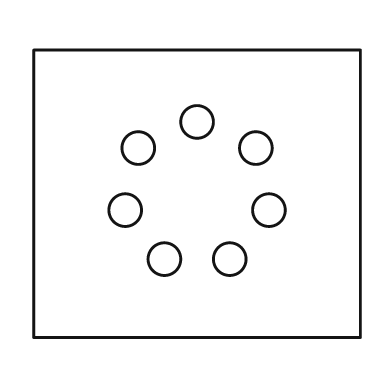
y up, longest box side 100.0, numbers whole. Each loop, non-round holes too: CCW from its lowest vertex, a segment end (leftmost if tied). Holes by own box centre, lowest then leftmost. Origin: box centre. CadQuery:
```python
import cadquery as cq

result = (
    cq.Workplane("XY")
    .moveTo(-50.0, -44.0)
    .lineTo(50.0, -44.0)
    .lineTo(50.0, 44.0)
    .lineTo(-50.0, 44.0)
    .close()
    .moveTo(-10.0, -20.0)
    .circle(5.0)
    .moveTo(10.0, -20.0)
    .circle(5.0)
    .moveTo(-22.0, -5.0)
    .circle(5.0)
    .moveTo(22.0, -5.0)
    .circle(5.0)
    .moveTo(-18.0, 14.0)
    .circle(5.0)
    .moveTo(18.0, 14.0)
    .circle(5.0)
    .moveTo(0.0, 22.0)
    .circle(5.0)
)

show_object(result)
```